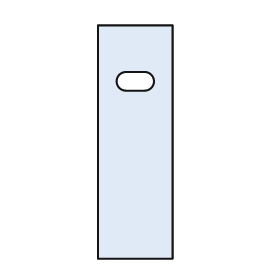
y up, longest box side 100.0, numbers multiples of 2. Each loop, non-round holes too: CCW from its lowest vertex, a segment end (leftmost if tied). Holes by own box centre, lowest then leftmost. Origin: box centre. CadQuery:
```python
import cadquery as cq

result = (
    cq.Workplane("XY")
    .moveTo(-16.0, -50.0)
    .lineTo(16.0, -50.0)
    .lineTo(16.0, 50.0)
    .lineTo(-16.0, 50.0)
    .close()
    .moveTo(-4.0, 22.0)
    .lineTo(4.0, 22.0)
    .threePointArc((8.0, 26.0), (4.0, 30.0))
    .lineTo(-4.0, 30.0)
    .threePointArc((-8.0, 26.0), (-4.0, 22.0))
    .close()
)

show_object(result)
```